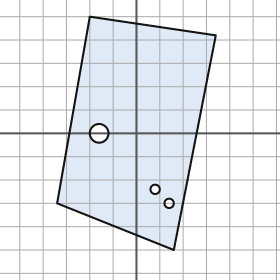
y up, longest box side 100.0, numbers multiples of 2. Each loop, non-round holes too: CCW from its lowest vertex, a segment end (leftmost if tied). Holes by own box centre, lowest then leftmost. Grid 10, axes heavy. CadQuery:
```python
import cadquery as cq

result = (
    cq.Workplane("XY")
    .moveTo(16.0, -50.0)
    .lineTo(34.0, 42.0)
    .lineTo(-20.0, 50.0)
    .lineTo(-34.0, -30.0)
    .close()
    .moveTo(14.0, -30.0)
    .circle(2.0)
    .moveTo(8.0, -24.0)
    .circle(2.0)
    .moveTo(-16.0, 0.0)
    .circle(4.0)
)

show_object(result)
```